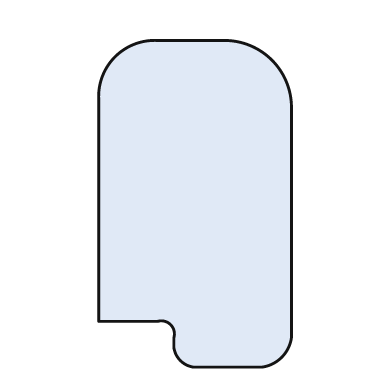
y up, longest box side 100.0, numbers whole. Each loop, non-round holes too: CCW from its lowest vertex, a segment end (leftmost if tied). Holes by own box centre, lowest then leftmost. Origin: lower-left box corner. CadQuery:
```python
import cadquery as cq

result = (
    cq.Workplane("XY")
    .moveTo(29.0, 0.0)
    .lineTo(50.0, 0.0)
    .threePointArc((56.0, 3.0), (59.0, 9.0))
    .lineTo(59.0, 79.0)
    .threePointArc((53.0, 94.0), (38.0, 100.0))
    .lineTo(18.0, 100.0)
    .threePointArc((5.0, 95.0), (0.0, 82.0))
    .lineTo(0.0, 14.0)
    .lineTo(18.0, 14.0)
    .threePointArc((22.0, 13.0), (23.0, 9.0))
    .lineTo(23.0, 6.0)
    .threePointArc((25.0, 2.0), (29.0, 0.0))
    .close()
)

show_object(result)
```